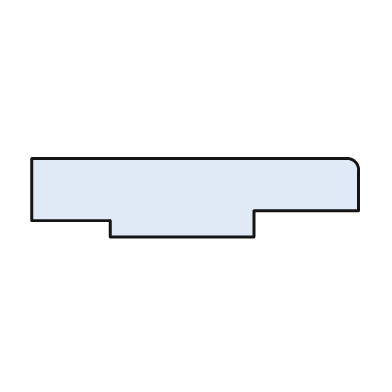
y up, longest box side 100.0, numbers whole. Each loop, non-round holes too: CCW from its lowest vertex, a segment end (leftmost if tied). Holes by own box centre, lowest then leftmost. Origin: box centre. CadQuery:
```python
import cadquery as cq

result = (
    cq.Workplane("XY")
    .moveTo(-26.0, -12.0)
    .lineTo(18.0, -12.0)
    .lineTo(18.0, -4.0)
    .lineTo(50.0, -4.0)
    .lineTo(50.0, 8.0)
    .threePointArc((49.0, 11.0), (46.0, 12.0))
    .lineTo(-50.0, 12.0)
    .lineTo(-50.0, -7.0)
    .lineTo(-26.0, -7.0)
    .close()
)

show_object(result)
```